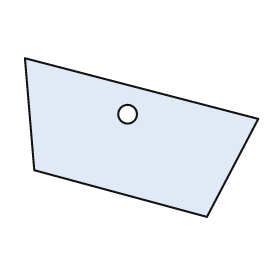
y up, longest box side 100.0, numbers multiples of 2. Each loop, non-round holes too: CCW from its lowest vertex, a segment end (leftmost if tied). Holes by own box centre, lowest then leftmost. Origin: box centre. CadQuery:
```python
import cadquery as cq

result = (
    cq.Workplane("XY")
    .moveTo(28.0, -34.0)
    .lineTo(50.0, 8.0)
    .lineTo(-50.0, 34.0)
    .lineTo(-46.0, -14.0)
    .close()
    .moveTo(-6.0, 10.0)
    .circle(4.0)
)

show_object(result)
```